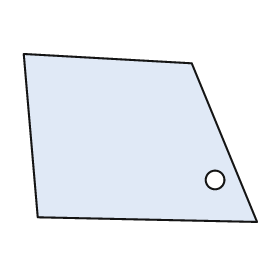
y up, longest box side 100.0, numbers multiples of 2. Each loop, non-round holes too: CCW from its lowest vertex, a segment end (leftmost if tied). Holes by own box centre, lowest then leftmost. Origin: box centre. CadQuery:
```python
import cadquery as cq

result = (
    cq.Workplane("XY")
    .moveTo(50.0, -36.0)
    .lineTo(22.0, 32.0)
    .lineTo(-50.0, 36.0)
    .lineTo(-44.0, -34.0)
    .close()
    .moveTo(32.0, -18.0)
    .circle(4.0)
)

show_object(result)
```